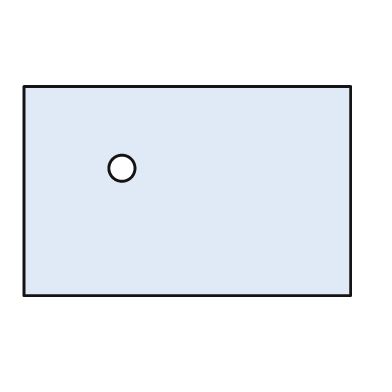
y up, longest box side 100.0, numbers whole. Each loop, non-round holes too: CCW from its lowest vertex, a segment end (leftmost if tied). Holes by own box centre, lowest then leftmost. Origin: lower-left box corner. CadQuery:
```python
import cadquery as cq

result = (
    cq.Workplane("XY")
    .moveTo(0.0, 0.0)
    .lineTo(100.0, 0.0)
    .lineTo(100.0, 64.0)
    .lineTo(0.0, 64.0)
    .close()
    .moveTo(30.0, 39.0)
    .circle(4.0)
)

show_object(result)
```